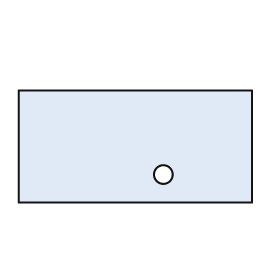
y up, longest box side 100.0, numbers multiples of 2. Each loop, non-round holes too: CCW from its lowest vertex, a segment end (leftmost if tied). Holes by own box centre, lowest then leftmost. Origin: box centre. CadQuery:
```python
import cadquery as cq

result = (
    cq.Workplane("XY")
    .moveTo(-50.0, -24.0)
    .lineTo(50.0, -24.0)
    .lineTo(50.0, 24.0)
    .lineTo(-50.0, 24.0)
    .close()
    .moveTo(12.0, -12.0)
    .circle(4.0)
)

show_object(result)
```